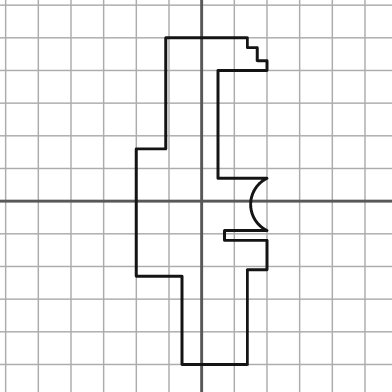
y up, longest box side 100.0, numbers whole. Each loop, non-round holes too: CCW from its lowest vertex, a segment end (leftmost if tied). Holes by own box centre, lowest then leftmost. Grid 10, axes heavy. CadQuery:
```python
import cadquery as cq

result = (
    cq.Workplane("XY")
    .moveTo(-6.0, -50.0)
    .lineTo(14.0, -50.0)
    .lineTo(14.0, -21.0)
    .lineTo(20.0, -21.0)
    .lineTo(20.0, -12.0)
    .lineTo(7.0, -12.0)
    .lineTo(7.0, -9.0)
    .lineTo(20.0, -9.0)
    .threePointArc((15.0, -1.0), (20.0, 7.0))
    .lineTo(5.0, 7.0)
    .lineTo(5.0, 40.0)
    .lineTo(20.0, 40.0)
    .lineTo(20.0, 43.0)
    .lineTo(17.0, 43.0)
    .lineTo(17.0, 47.0)
    .lineTo(14.0, 47.0)
    .lineTo(14.0, 50.0)
    .lineTo(-11.0, 50.0)
    .lineTo(-11.0, 16.0)
    .lineTo(-20.0, 16.0)
    .lineTo(-20.0, -23.0)
    .lineTo(-6.0, -23.0)
    .close()
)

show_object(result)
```